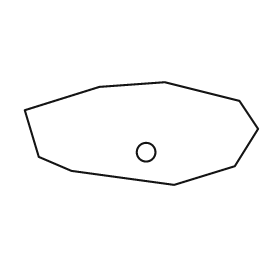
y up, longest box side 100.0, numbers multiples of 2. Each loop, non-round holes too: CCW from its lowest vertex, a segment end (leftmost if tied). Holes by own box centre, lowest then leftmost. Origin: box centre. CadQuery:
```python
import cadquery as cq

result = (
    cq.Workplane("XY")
    .moveTo(14.0, -22.0)
    .lineTo(40.0, -14.0)
    .lineTo(50.0, 2.0)
    .lineTo(42.0, 14.0)
    .lineTo(10.0, 22.0)
    .lineTo(-18.0, 20.0)
    .lineTo(-50.0, 10.0)
    .lineTo(-44.0, -10.0)
    .lineTo(-30.0, -16.0)
    .close()
    .moveTo(2.0, -8.0)
    .circle(4.0)
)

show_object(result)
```